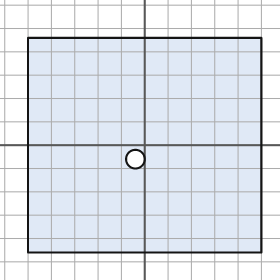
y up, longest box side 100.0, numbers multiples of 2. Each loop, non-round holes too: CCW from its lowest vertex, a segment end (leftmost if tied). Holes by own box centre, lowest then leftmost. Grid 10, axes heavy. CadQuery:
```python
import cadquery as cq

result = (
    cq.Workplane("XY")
    .moveTo(-50.0, -46.0)
    .lineTo(50.0, -46.0)
    .lineTo(50.0, 46.0)
    .lineTo(-50.0, 46.0)
    .close()
    .moveTo(-4.0, -6.0)
    .circle(4.0)
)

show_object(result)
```